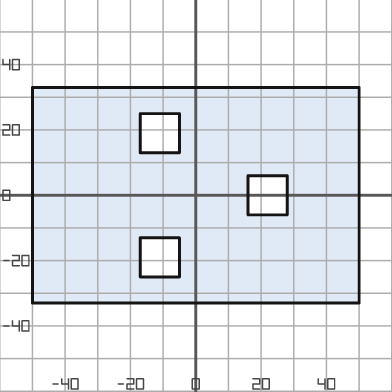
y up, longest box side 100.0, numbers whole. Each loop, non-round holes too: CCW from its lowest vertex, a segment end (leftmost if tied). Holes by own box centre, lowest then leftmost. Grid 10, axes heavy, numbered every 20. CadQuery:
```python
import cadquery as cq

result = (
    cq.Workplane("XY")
    .moveTo(-50.0, -33.0)
    .lineTo(50.0, -33.0)
    .lineTo(50.0, 33.0)
    .lineTo(-50.0, 33.0)
    .close()
    .moveTo(-17.0, -25.0)
    .lineTo(-5.0, -25.0)
    .lineTo(-5.0, -13.0)
    .lineTo(-17.0, -13.0)
    .close()
    .moveTo(16.0, -6.0)
    .lineTo(28.0, -6.0)
    .lineTo(28.0, 6.0)
    .lineTo(16.0, 6.0)
    .close()
    .moveTo(-17.0, 13.0)
    .lineTo(-5.0, 13.0)
    .lineTo(-5.0, 25.0)
    .lineTo(-17.0, 25.0)
    .close()
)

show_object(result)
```